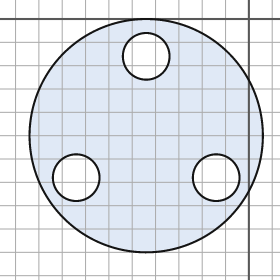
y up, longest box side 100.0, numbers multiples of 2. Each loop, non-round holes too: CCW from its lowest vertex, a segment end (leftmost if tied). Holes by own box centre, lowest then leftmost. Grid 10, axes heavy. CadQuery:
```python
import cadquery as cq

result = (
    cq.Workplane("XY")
    .moveTo(-44.0, -50.0)
    .circle(50.0)
    .moveTo(-74.0, -68.0)
    .circle(10.0)
    .moveTo(-14.0, -68.0)
    .circle(10.0)
    .moveTo(-44.0, -16.0)
    .circle(10.0)
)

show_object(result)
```